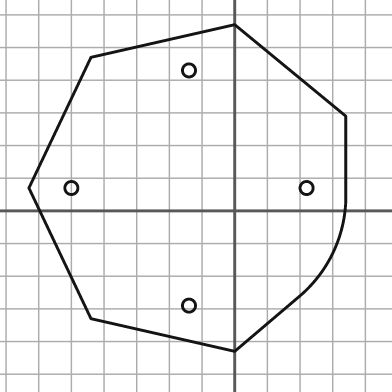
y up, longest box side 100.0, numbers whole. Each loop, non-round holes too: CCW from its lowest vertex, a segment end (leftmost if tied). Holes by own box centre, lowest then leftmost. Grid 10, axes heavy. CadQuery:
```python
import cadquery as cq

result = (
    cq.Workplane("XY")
    .moveTo(0.0, -43.0)
    .lineTo(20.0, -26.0)
    .threePointArc((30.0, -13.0), (34.0, 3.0))
    .lineTo(34.0, 29.0)
    .lineTo(0.0, 57.0)
    .lineTo(-44.0, 47.0)
    .lineTo(-63.0, 7.0)
    .lineTo(-44.0, -33.0)
    .close()
    .moveTo(-14.0, -29.0)
    .circle(2.0)
    .moveTo(-50.0, 7.0)
    .circle(2.0)
    .moveTo(22.0, 7.0)
    .circle(2.0)
    .moveTo(-14.0, 43.0)
    .circle(2.0)
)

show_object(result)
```